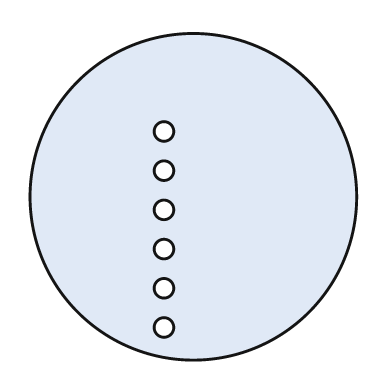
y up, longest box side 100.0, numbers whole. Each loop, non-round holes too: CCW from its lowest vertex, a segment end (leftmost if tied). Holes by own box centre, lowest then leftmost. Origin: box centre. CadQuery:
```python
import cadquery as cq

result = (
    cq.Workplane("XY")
    .moveTo(0.0, 0.0)
    .circle(50.0)
    .moveTo(-9.0, -40.0)
    .circle(3.0)
    .moveTo(-9.0, -28.0)
    .circle(3.0)
    .moveTo(-9.0, -16.0)
    .circle(3.0)
    .moveTo(-9.0, -4.0)
    .circle(3.0)
    .moveTo(-9.0, 8.0)
    .circle(3.0)
    .moveTo(-9.0, 20.0)
    .circle(3.0)
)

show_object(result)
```